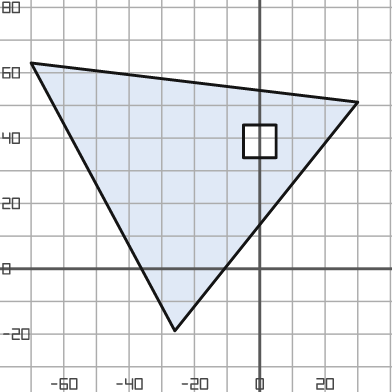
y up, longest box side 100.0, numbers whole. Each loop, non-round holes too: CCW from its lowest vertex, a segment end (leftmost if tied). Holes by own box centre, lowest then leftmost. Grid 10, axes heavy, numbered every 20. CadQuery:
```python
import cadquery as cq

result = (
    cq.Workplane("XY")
    .moveTo(-26.0, -19.0)
    .lineTo(30.0, 51.0)
    .lineTo(-70.0, 63.0)
    .close()
    .moveTo(-5.0, 34.0)
    .lineTo(5.0, 34.0)
    .lineTo(5.0, 44.0)
    .lineTo(-5.0, 44.0)
    .close()
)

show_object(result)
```